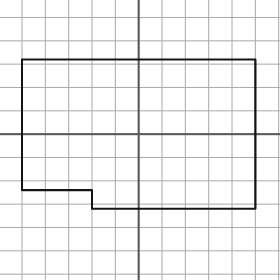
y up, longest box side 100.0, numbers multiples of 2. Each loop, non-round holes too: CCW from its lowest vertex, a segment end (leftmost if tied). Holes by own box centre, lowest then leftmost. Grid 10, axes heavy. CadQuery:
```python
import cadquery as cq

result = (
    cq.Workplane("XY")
    .moveTo(-20.0, -32.0)
    .lineTo(50.0, -32.0)
    .lineTo(50.0, 32.0)
    .lineTo(-50.0, 32.0)
    .lineTo(-50.0, -24.0)
    .lineTo(-20.0, -24.0)
    .close()
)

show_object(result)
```